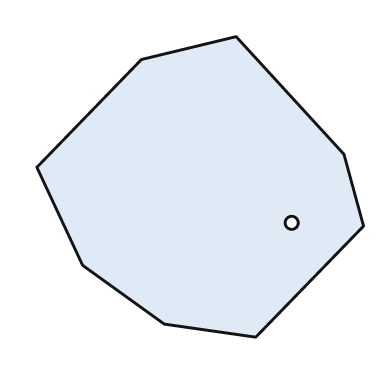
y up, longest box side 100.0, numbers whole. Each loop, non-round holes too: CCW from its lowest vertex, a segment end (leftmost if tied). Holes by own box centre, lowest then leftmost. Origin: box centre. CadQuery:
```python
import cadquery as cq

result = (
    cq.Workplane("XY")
    .moveTo(17.0, -46.0)
    .lineTo(50.0, -12.0)
    .lineTo(44.0, 10.0)
    .lineTo(11.0, 46.0)
    .lineTo(-18.0, 39.0)
    .lineTo(-50.0, 6.0)
    .lineTo(-36.0, -24.0)
    .lineTo(-11.0, -42.0)
    .close()
    .moveTo(28.0, -11.0)
    .circle(2.0)
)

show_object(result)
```